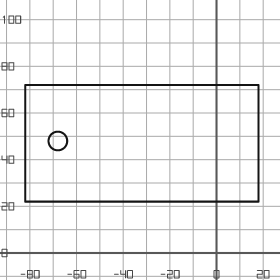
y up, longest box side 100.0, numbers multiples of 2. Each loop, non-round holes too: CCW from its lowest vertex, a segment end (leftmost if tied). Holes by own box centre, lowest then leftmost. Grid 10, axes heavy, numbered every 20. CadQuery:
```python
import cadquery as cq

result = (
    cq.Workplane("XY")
    .moveTo(-82.0, 22.0)
    .lineTo(18.0, 22.0)
    .lineTo(18.0, 72.0)
    .lineTo(-82.0, 72.0)
    .close()
    .moveTo(-68.0, 48.0)
    .circle(4.0)
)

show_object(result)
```